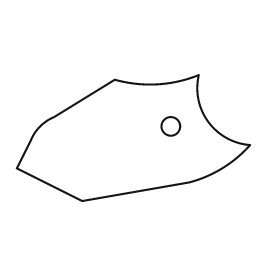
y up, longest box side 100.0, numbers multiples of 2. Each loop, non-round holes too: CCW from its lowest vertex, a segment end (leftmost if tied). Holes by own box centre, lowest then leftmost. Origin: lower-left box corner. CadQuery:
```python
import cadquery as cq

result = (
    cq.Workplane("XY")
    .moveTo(28.0, 0.0)
    .lineTo(74.0, 8.0)
    .threePointArc((88.0, 14.0), (100.0, 24.0))
    .threePointArc((82.0, 34.0), (78.0, 54.0))
    .threePointArc((60.0, 50.0), (42.0, 52.0))
    .lineTo(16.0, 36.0)
    .threePointArc((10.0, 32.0), (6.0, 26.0))
    .lineTo(0.0, 14.0)
    .close()
    .moveTo(66.0, 32.0)
    .circle(4.0)
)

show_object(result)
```